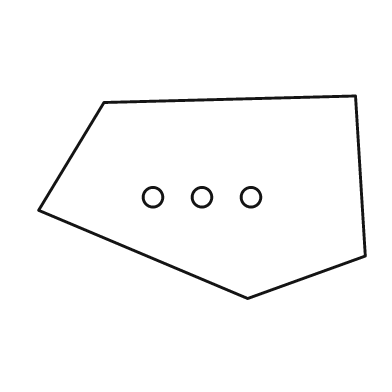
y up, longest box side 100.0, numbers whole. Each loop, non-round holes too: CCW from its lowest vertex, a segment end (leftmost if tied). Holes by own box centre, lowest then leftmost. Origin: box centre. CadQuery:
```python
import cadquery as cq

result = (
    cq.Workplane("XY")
    .moveTo(14.0, -31.0)
    .lineTo(50.0, -18.0)
    .lineTo(47.0, 31.0)
    .lineTo(-30.0, 29.0)
    .lineTo(-50.0, -4.0)
    .close()
    .moveTo(-15.0, 0.0)
    .circle(3.0)
    .moveTo(0.0, 0.0)
    .circle(3.0)
    .moveTo(15.0, 0.0)
    .circle(3.0)
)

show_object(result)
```